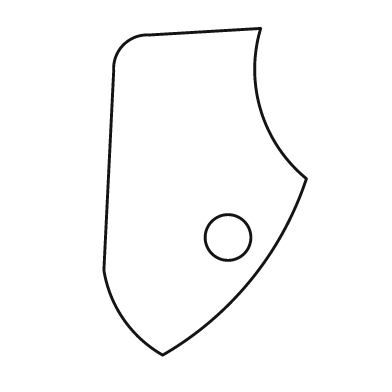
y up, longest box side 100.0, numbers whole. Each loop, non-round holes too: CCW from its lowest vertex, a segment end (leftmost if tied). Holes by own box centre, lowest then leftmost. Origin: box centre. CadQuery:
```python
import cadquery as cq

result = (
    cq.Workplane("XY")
    .moveTo(-13.0, -50.0)
    .threePointArc((14.0, -27.0), (31.0, 4.0))
    .threePointArc((17.0, 25.0), (17.0, 50.0))
    .lineTo(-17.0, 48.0)
    .threePointArc((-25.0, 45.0), (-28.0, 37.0))
    .lineTo(-31.0, -24.0)
    .threePointArc((-25.0, -39.0), (-13.0, -50.0))
    .close()
    .moveTo(7.0, -14.0)
    .circle(7.0)
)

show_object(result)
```